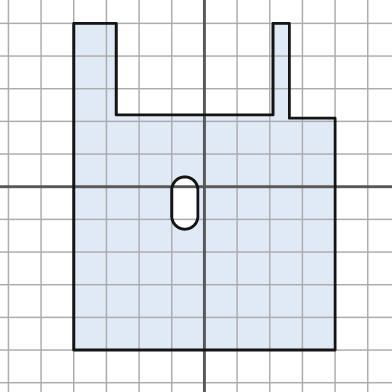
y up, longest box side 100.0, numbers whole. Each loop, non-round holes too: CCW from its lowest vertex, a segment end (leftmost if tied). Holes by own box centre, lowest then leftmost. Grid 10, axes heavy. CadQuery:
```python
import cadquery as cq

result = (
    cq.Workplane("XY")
    .moveTo(-40.0, -50.0)
    .lineTo(40.0, -50.0)
    .lineTo(40.0, 21.0)
    .lineTo(26.0, 21.0)
    .lineTo(26.0, 50.0)
    .lineTo(21.0, 50.0)
    .lineTo(21.0, 22.0)
    .lineTo(-27.0, 22.0)
    .lineTo(-27.0, 50.0)
    .lineTo(-40.0, 50.0)
    .close()
    .moveTo(-10.0, -9.0)
    .threePointArc((-6.0, -13.0), (-2.0, -9.0))
    .lineTo(-2.0, -1.0)
    .threePointArc((-6.0, 3.0), (-10.0, -1.0))
    .close()
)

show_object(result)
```